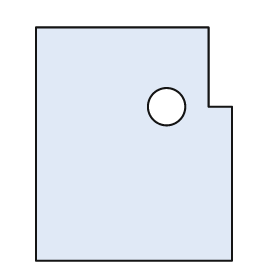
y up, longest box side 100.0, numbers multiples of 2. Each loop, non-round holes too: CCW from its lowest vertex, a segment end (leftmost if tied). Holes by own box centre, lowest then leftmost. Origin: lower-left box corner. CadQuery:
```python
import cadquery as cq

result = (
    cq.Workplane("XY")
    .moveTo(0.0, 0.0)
    .lineTo(84.0, 0.0)
    .lineTo(84.0, 66.0)
    .lineTo(74.0, 66.0)
    .lineTo(74.0, 100.0)
    .lineTo(0.0, 100.0)
    .close()
    .moveTo(56.0, 66.0)
    .circle(8.0)
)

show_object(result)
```